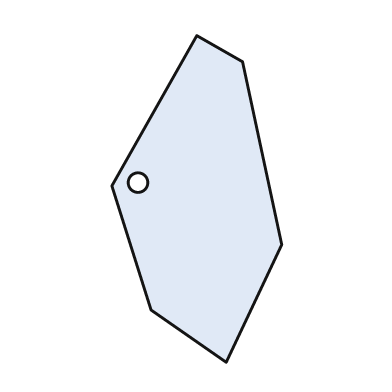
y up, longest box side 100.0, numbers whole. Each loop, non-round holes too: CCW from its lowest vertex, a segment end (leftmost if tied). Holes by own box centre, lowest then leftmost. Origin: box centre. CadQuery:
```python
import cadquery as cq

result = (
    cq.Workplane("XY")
    .moveTo(9.0, -50.0)
    .lineTo(26.0, -14.0)
    .lineTo(14.0, 42.0)
    .lineTo(0.0, 50.0)
    .lineTo(-26.0, 4.0)
    .lineTo(-14.0, -34.0)
    .close()
    .moveTo(-18.0, 5.0)
    .circle(3.0)
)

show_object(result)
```